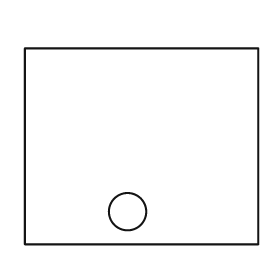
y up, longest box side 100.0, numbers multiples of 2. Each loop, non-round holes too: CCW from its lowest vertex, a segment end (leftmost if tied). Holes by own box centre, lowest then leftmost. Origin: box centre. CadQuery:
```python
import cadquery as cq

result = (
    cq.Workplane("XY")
    .moveTo(-50.0, -42.0)
    .lineTo(50.0, -42.0)
    .lineTo(50.0, 42.0)
    .lineTo(-50.0, 42.0)
    .close()
    .moveTo(-6.0, -28.0)
    .circle(8.0)
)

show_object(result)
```